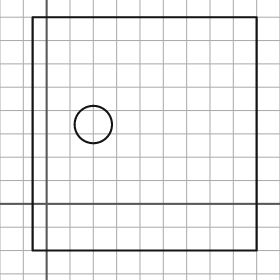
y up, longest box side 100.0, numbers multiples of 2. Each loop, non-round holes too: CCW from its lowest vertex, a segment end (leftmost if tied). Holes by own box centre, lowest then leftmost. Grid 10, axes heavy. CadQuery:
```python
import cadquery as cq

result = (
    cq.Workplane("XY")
    .moveTo(-6.0, -20.0)
    .lineTo(90.0, -20.0)
    .lineTo(90.0, 80.0)
    .lineTo(-6.0, 80.0)
    .close()
    .moveTo(20.0, 34.0)
    .circle(8.0)
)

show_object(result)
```